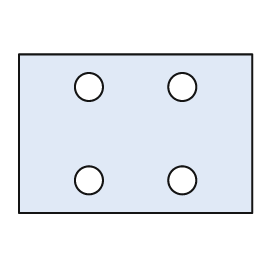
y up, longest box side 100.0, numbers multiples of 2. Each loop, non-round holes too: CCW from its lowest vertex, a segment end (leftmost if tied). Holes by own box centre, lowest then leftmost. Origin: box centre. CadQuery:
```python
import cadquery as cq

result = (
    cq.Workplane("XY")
    .moveTo(-50.0, -34.0)
    .lineTo(50.0, -34.0)
    .lineTo(50.0, 34.0)
    .lineTo(-50.0, 34.0)
    .close()
    .moveTo(-20.0, -20.0)
    .circle(6.0)
    .moveTo(20.0, -20.0)
    .circle(6.0)
    .moveTo(-20.0, 20.0)
    .circle(6.0)
    .moveTo(20.0, 20.0)
    .circle(6.0)
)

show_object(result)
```